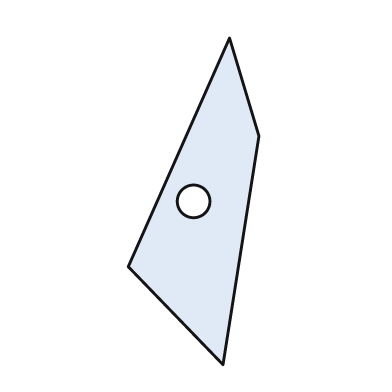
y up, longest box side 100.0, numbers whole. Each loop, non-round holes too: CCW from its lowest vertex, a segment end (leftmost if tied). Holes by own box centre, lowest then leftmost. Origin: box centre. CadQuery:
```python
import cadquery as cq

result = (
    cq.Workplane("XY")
    .moveTo(9.0, -50.0)
    .lineTo(20.0, 20.0)
    .lineTo(11.0, 50.0)
    .lineTo(-20.0, -20.0)
    .close()
    .moveTo(0.0, 0.0)
    .circle(5.0)
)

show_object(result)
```